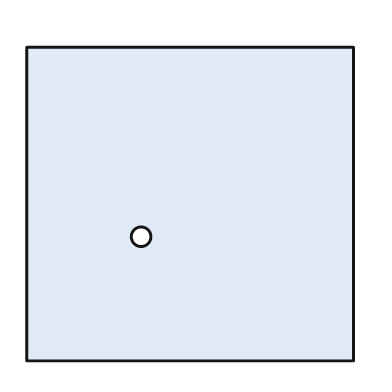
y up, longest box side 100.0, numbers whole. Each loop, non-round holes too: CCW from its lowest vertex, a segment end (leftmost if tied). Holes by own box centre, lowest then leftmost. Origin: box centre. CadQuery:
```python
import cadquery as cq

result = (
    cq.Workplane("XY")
    .moveTo(-50.0, -48.0)
    .lineTo(50.0, -48.0)
    .lineTo(50.0, 48.0)
    .lineTo(-50.0, 48.0)
    .close()
    .moveTo(-15.0, -10.0)
    .circle(3.0)
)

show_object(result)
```